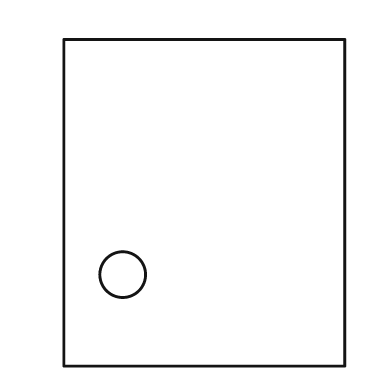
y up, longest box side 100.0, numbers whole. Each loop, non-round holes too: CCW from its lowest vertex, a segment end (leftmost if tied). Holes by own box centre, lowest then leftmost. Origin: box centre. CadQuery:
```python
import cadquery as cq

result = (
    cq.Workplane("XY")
    .moveTo(-43.0, -50.0)
    .lineTo(43.0, -50.0)
    .lineTo(43.0, 50.0)
    .lineTo(-43.0, 50.0)
    .close()
    .moveTo(-25.0, -22.0)
    .circle(7.0)
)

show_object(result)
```